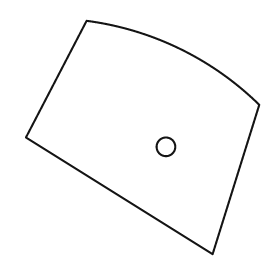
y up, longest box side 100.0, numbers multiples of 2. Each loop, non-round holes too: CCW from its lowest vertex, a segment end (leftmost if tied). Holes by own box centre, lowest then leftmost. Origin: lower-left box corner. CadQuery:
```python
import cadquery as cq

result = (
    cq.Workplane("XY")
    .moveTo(80.0, 0.0)
    .lineTo(100.0, 64.0)
    .threePointArc((66.0, 88.0), (26.0, 100.0))
    .lineTo(0.0, 50.0)
    .close()
    .moveTo(60.0, 46.0)
    .circle(4.0)
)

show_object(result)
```